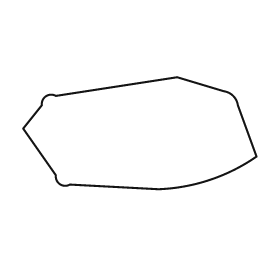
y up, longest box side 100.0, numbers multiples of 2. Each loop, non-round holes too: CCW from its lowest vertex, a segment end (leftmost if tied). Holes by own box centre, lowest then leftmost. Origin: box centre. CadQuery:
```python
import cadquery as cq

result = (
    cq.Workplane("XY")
    .moveTo(8.0, -24.0)
    .threePointArc((30.0, -20.0), (50.0, -10.0))
    .lineTo(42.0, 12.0)
    .threePointArc((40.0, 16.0), (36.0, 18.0))
    .lineTo(16.0, 24.0)
    .lineTo(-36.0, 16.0)
    .threePointArc((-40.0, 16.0), (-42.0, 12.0))
    .lineTo(-50.0, 2.0)
    .lineTo(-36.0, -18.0)
    .threePointArc((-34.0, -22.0), (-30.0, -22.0))
    .close()
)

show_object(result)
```